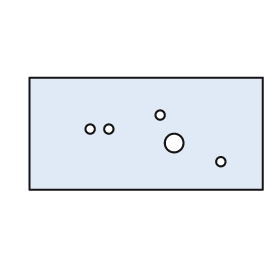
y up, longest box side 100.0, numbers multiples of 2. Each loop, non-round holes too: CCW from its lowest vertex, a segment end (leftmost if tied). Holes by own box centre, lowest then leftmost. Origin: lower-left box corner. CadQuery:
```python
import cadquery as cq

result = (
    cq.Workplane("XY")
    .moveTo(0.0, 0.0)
    .lineTo(100.0, 0.0)
    .lineTo(100.0, 48.0)
    .lineTo(0.0, 48.0)
    .close()
    .moveTo(82.0, 12.0)
    .circle(2.0)
    .moveTo(62.0, 20.0)
    .circle(4.0)
    .moveTo(26.0, 26.0)
    .circle(2.0)
    .moveTo(34.0, 26.0)
    .circle(2.0)
    .moveTo(56.0, 32.0)
    .circle(2.0)
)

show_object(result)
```